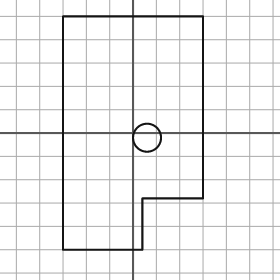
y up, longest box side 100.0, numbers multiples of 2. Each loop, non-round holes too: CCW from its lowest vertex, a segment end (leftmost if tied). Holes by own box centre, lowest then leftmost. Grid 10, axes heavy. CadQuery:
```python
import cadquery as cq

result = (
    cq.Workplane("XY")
    .moveTo(-30.0, -50.0)
    .lineTo(4.0, -50.0)
    .lineTo(4.0, -28.0)
    .lineTo(30.0, -28.0)
    .lineTo(30.0, 50.0)
    .lineTo(-30.0, 50.0)
    .close()
    .moveTo(6.0, -2.0)
    .circle(6.0)
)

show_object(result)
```